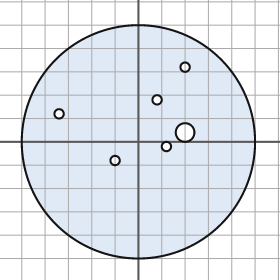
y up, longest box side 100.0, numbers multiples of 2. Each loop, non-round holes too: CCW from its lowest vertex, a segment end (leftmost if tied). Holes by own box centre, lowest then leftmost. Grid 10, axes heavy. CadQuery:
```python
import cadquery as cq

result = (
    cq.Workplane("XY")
    .moveTo(0.0, 0.0)
    .circle(50.0)
    .moveTo(-10.0, -8.0)
    .circle(2.0)
    .moveTo(12.0, -2.0)
    .circle(2.0)
    .moveTo(20.0, 4.0)
    .circle(4.0)
    .moveTo(-34.0, 12.0)
    .circle(2.0)
    .moveTo(8.0, 18.0)
    .circle(2.0)
    .moveTo(20.0, 32.0)
    .circle(2.0)
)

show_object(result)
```